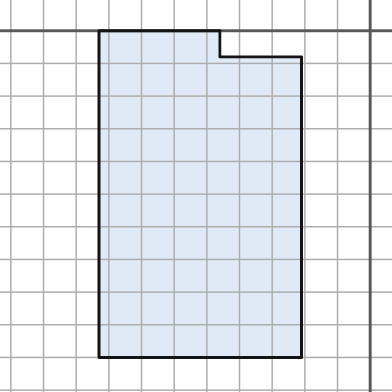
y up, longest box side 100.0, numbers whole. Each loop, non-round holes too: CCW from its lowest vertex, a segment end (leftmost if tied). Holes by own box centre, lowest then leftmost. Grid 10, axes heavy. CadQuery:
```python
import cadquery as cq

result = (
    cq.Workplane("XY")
    .moveTo(-83.0, -100.0)
    .lineTo(-21.0, -100.0)
    .lineTo(-21.0, -8.0)
    .lineTo(-46.0, -8.0)
    .lineTo(-46.0, 0.0)
    .lineTo(-83.0, 0.0)
    .close()
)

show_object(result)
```